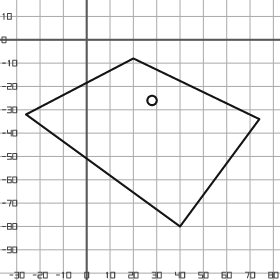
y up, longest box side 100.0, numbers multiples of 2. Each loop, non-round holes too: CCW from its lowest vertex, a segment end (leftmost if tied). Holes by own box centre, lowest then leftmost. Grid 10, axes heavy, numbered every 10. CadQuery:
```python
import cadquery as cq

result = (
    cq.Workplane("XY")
    .moveTo(40.0, -80.0)
    .lineTo(74.0, -34.0)
    .lineTo(20.0, -8.0)
    .lineTo(-26.0, -32.0)
    .close()
    .moveTo(28.0, -26.0)
    .circle(2.0)
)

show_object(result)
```